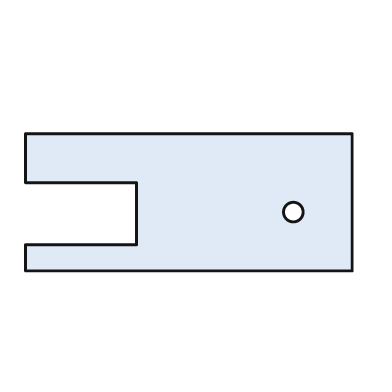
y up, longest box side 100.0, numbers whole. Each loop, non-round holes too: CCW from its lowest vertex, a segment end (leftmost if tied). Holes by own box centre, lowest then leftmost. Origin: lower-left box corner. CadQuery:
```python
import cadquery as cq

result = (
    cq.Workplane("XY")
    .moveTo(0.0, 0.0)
    .lineTo(100.0, 0.0)
    .lineTo(100.0, 42.0)
    .lineTo(0.0, 42.0)
    .lineTo(0.0, 27.0)
    .lineTo(34.0, 27.0)
    .lineTo(34.0, 8.0)
    .lineTo(0.0, 8.0)
    .close()
    .moveTo(82.0, 18.0)
    .circle(3.0)
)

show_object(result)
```